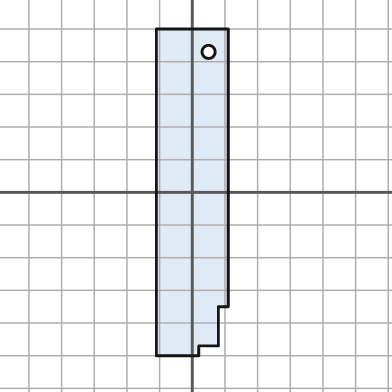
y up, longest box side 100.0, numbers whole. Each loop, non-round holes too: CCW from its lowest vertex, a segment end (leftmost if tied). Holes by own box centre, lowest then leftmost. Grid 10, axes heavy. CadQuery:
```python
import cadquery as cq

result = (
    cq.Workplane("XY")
    .moveTo(-11.0, -50.0)
    .lineTo(2.0, -50.0)
    .lineTo(2.0, -47.0)
    .lineTo(8.0, -47.0)
    .lineTo(8.0, -35.0)
    .lineTo(11.0, -35.0)
    .lineTo(11.0, 50.0)
    .lineTo(-11.0, 50.0)
    .close()
    .moveTo(5.0, 43.0)
    .circle(2.0)
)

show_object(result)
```